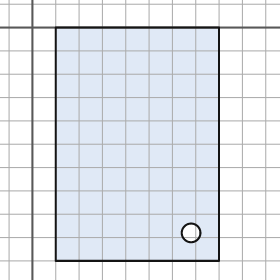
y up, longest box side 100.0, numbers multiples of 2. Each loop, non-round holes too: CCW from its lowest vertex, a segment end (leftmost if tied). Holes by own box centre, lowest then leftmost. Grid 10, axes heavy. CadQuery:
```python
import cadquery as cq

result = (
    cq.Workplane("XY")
    .moveTo(10.0, -100.0)
    .lineTo(80.0, -100.0)
    .lineTo(80.0, 0.0)
    .lineTo(10.0, 0.0)
    .close()
    .moveTo(68.0, -88.0)
    .circle(4.0)
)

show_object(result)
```